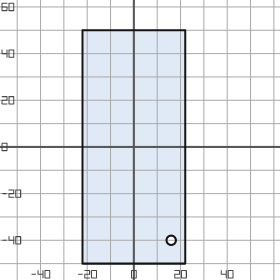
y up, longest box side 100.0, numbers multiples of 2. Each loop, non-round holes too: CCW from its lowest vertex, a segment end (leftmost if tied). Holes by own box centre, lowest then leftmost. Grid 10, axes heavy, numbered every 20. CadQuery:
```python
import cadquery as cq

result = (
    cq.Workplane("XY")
    .moveTo(-22.0, -50.0)
    .lineTo(22.0, -50.0)
    .lineTo(22.0, 50.0)
    .lineTo(-22.0, 50.0)
    .close()
    .moveTo(16.0, -40.0)
    .circle(2.0)
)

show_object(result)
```